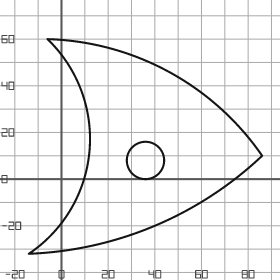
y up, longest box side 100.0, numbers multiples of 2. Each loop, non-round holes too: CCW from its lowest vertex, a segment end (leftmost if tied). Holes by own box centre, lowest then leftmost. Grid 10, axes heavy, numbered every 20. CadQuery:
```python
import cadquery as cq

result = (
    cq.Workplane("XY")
    .moveTo(-14.0, -32.0)
    .threePointArc((40.0, -20.0), (86.0, 10.0))
    .threePointArc((46.0, 46.0), (-6.0, 60.0))
    .threePointArc((12.0, 12.0), (-14.0, -32.0))
    .close()
    .moveTo(36.0, 8.0)
    .circle(8.0)
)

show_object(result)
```